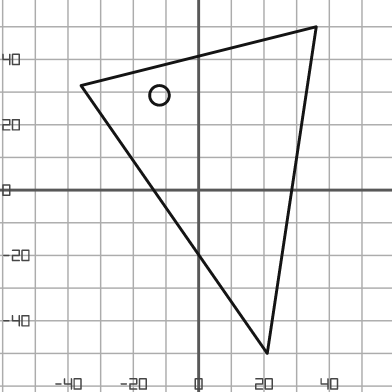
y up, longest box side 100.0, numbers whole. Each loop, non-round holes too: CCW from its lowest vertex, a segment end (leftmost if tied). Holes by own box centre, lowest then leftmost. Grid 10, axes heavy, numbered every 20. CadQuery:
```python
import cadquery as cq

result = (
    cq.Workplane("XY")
    .moveTo(21.0, -50.0)
    .lineTo(36.0, 50.0)
    .lineTo(-36.0, 32.0)
    .close()
    .moveTo(-12.0, 29.0)
    .circle(3.0)
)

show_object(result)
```